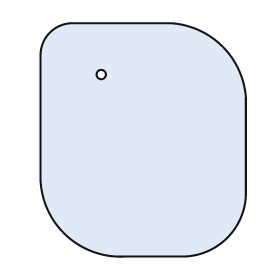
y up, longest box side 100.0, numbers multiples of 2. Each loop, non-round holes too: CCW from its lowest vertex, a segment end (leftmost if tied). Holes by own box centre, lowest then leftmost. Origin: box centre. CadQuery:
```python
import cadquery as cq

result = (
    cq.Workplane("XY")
    .moveTo(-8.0, -50.0)
    .lineTo(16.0, -50.0)
    .threePointArc((36.0, -42.0), (44.0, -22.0))
    .lineTo(44.0, 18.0)
    .threePointArc((34.0, 40.0), (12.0, 50.0))
    .lineTo(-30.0, 50.0)
    .threePointArc((-40.0, 46.0), (-44.0, 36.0))
    .lineTo(-44.0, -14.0)
    .threePointArc((-34.0, -40.0), (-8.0, -50.0))
    .close()
    .moveTo(-18.0, 28.0)
    .circle(2.0)
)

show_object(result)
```